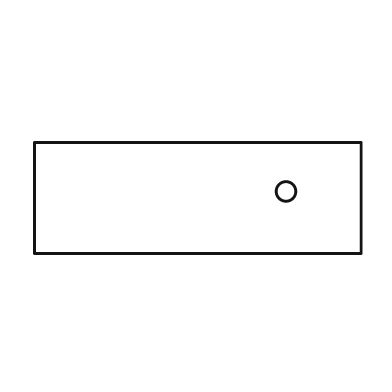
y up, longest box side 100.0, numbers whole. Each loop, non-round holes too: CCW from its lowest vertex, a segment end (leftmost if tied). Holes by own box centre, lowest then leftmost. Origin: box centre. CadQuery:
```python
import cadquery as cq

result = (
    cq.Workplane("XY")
    .moveTo(-50.0, -17.0)
    .lineTo(50.0, -17.0)
    .lineTo(50.0, 17.0)
    .lineTo(-50.0, 17.0)
    .close()
    .moveTo(27.0, 2.0)
    .circle(3.0)
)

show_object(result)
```